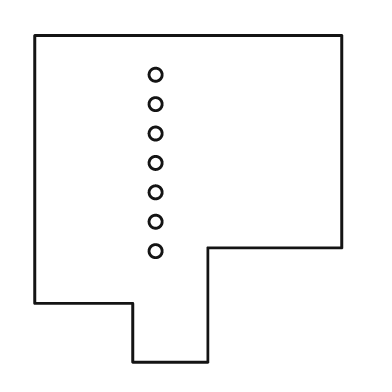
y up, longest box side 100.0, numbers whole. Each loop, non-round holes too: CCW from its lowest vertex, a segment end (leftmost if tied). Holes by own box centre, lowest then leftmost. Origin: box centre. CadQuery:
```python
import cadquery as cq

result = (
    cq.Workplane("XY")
    .moveTo(-17.0, -50.0)
    .lineTo(6.0, -50.0)
    .lineTo(6.0, -15.0)
    .lineTo(47.0, -15.0)
    .lineTo(47.0, 50.0)
    .lineTo(-47.0, 50.0)
    .lineTo(-47.0, -32.0)
    .lineTo(-17.0, -32.0)
    .close()
    .moveTo(-10.0, -16.0)
    .circle(2.0)
    .moveTo(-10.0, -7.0)
    .circle(2.0)
    .moveTo(-10.0, 2.0)
    .circle(2.0)
    .moveTo(-10.0, 11.0)
    .circle(2.0)
    .moveTo(-10.0, 20.0)
    .circle(2.0)
    .moveTo(-10.0, 29.0)
    .circle(2.0)
    .moveTo(-10.0, 38.0)
    .circle(2.0)
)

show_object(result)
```